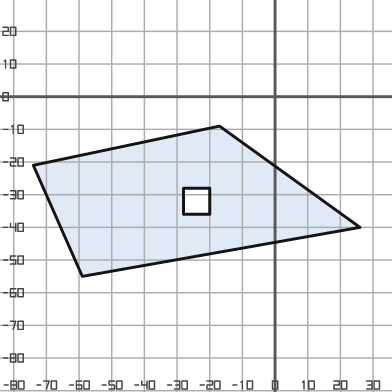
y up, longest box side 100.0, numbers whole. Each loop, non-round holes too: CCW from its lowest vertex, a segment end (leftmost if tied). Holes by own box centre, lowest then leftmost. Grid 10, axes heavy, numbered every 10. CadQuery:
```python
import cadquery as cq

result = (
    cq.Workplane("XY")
    .moveTo(-59.0, -55.0)
    .lineTo(26.0, -40.0)
    .lineTo(-17.0, -9.0)
    .lineTo(-74.0, -21.0)
    .close()
    .moveTo(-28.0, -36.0)
    .lineTo(-20.0, -36.0)
    .lineTo(-20.0, -28.0)
    .lineTo(-28.0, -28.0)
    .close()
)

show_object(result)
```